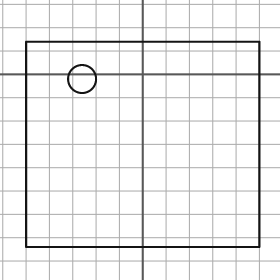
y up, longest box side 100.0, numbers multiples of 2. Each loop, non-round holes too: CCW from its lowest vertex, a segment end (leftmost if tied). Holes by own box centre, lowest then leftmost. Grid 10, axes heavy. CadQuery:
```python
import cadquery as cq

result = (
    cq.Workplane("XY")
    .moveTo(-50.0, -74.0)
    .lineTo(50.0, -74.0)
    .lineTo(50.0, 14.0)
    .lineTo(-50.0, 14.0)
    .close()
    .moveTo(-26.0, -2.0)
    .circle(6.0)
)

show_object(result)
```